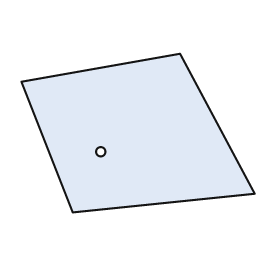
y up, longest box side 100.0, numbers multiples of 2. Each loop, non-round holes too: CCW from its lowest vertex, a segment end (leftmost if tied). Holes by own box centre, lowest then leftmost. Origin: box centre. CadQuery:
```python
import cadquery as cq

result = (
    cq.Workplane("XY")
    .moveTo(-28.0, -34.0)
    .lineTo(50.0, -26.0)
    .lineTo(18.0, 34.0)
    .lineTo(-50.0, 22.0)
    .close()
    .moveTo(-16.0, -8.0)
    .circle(2.0)
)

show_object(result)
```